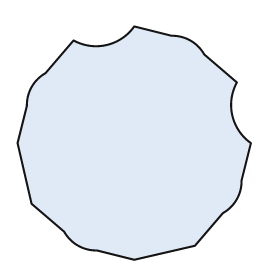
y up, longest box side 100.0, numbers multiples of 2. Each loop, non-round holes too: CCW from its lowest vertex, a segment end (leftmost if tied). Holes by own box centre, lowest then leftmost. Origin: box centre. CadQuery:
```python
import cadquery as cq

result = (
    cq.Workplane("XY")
    .moveTo(0.0, -50.0)
    .lineTo(26.0, -44.0)
    .lineTo(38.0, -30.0)
    .threePointArc((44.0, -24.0), (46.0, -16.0))
    .lineTo(50.0, 0.0)
    .threePointArc((42.0, 12.0), (44.0, 26.0))
    .lineTo(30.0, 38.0)
    .threePointArc((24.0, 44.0), (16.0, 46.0))
    .lineTo(0.0, 50.0)
    .threePointArc((-12.0, 42.0), (-26.0, 44.0))
    .lineTo(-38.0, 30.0)
    .threePointArc((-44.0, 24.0), (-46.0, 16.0))
    .lineTo(-50.0, 0.0)
    .lineTo(-44.0, -26.0)
    .lineTo(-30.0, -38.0)
    .threePointArc((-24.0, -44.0), (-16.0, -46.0))
    .close()
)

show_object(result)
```